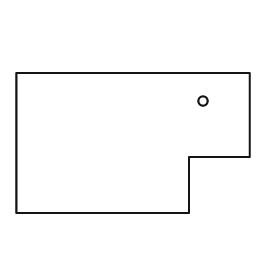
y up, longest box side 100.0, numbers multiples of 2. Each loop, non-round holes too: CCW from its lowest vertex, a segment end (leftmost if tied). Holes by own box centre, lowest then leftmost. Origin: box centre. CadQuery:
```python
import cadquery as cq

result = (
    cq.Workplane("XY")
    .moveTo(-50.0, -30.0)
    .lineTo(24.0, -30.0)
    .lineTo(24.0, -6.0)
    .lineTo(50.0, -6.0)
    .lineTo(50.0, 30.0)
    .lineTo(-50.0, 30.0)
    .close()
    .moveTo(30.0, 18.0)
    .circle(2.0)
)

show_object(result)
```